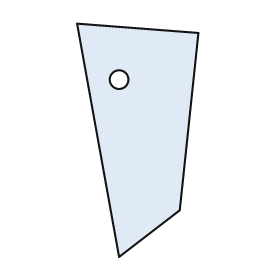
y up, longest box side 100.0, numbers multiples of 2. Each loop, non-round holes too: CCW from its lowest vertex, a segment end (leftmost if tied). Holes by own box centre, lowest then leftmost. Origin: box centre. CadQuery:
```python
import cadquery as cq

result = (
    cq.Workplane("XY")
    .moveTo(-8.0, -50.0)
    .lineTo(18.0, -30.0)
    .lineTo(26.0, 46.0)
    .lineTo(-26.0, 50.0)
    .close()
    .moveTo(-8.0, 26.0)
    .circle(4.0)
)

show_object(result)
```